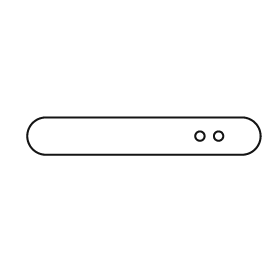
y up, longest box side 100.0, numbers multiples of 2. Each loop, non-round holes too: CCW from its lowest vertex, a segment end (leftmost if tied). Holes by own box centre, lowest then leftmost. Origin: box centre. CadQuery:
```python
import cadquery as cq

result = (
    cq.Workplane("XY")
    .moveTo(-42.0, -8.0)
    .lineTo(42.0, -8.0)
    .threePointArc((50.0, 0.0), (42.0, 8.0))
    .lineTo(-42.0, 8.0)
    .threePointArc((-50.0, 0.0), (-42.0, -8.0))
    .close()
    .moveTo(24.0, 0.0)
    .circle(2.0)
    .moveTo(32.0, 0.0)
    .circle(2.0)
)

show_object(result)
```